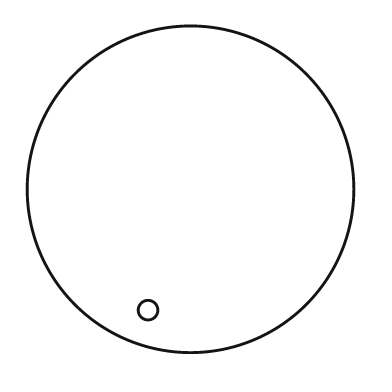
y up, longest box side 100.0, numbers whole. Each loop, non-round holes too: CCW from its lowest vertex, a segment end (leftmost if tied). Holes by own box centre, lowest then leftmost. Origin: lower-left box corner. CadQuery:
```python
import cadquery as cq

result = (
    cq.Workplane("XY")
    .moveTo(50.0, 50.0)
    .circle(50.0)
    .moveTo(37.0, 13.0)
    .circle(3.0)
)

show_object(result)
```